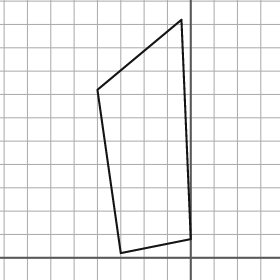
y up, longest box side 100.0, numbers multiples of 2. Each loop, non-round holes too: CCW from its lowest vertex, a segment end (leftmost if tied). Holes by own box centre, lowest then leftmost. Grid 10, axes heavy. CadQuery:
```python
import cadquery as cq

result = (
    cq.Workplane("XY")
    .moveTo(-30.0, 2.0)
    .lineTo(0.0, 8.0)
    .lineTo(-4.0, 102.0)
    .lineTo(-40.0, 72.0)
    .close()
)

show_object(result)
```